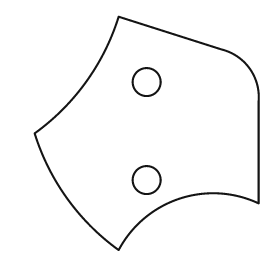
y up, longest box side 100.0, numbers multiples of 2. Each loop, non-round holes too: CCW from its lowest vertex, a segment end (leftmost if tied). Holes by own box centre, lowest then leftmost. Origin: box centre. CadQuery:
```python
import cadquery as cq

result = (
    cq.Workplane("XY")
    .moveTo(-12.0, -50.0)
    .threePointArc((14.0, -28.0), (48.0, -30.0))
    .lineTo(48.0, 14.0)
    .threePointArc((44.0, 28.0), (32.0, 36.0))
    .lineTo(-12.0, 50.0)
    .threePointArc((-26.0, 22.0), (-48.0, 0.0))
    .threePointArc((-34.0, -28.0), (-12.0, -50.0))
    .close()
    .moveTo(0.0, -20.0)
    .circle(6.0)
    .moveTo(0.0, 22.0)
    .circle(6.0)
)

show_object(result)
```